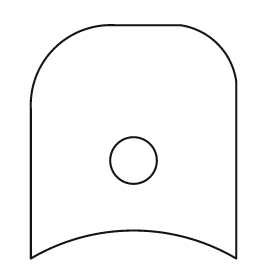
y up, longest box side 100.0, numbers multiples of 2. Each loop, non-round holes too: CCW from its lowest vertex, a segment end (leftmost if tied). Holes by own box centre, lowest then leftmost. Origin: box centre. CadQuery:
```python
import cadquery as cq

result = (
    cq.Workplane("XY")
    .moveTo(-44.0, -50.0)
    .threePointArc((0.0, -38.0), (44.0, -50.0))
    .lineTo(44.0, 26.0)
    .threePointArc((36.0, 42.0), (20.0, 50.0))
    .lineTo(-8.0, 50.0)
    .threePointArc((-34.0, 40.0), (-44.0, 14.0))
    .close()
    .moveTo(0.0, -8.0)
    .circle(10.0)
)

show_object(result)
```